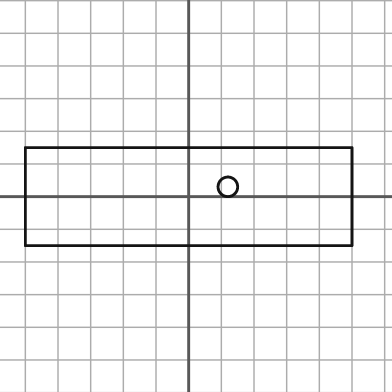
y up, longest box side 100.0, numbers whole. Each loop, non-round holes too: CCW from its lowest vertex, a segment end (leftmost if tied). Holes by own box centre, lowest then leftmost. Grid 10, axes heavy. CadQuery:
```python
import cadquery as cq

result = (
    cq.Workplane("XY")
    .moveTo(-50.0, -15.0)
    .lineTo(50.0, -15.0)
    .lineTo(50.0, 15.0)
    .lineTo(-50.0, 15.0)
    .close()
    .moveTo(12.0, 3.0)
    .circle(3.0)
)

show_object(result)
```